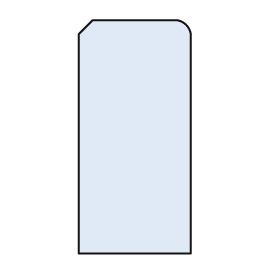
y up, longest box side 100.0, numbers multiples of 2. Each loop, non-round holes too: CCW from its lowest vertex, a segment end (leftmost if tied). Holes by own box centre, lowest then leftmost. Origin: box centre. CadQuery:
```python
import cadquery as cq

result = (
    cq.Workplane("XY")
    .moveTo(-24.0, -50.0)
    .lineTo(24.0, -50.0)
    .lineTo(24.0, 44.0)
    .threePointArc((22.0, 48.0), (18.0, 50.0))
    .lineTo(-18.0, 50.0)
    .lineTo(-24.0, 44.0)
    .close()
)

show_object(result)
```